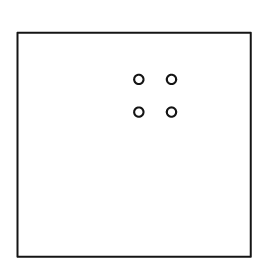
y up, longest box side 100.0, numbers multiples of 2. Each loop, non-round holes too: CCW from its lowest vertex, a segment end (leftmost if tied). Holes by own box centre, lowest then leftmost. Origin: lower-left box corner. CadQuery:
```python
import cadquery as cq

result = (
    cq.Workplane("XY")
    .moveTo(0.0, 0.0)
    .lineTo(100.0, 0.0)
    .lineTo(100.0, 96.0)
    .lineTo(0.0, 96.0)
    .close()
    .moveTo(52.0, 62.0)
    .circle(2.0)
    .moveTo(66.0, 62.0)
    .circle(2.0)
    .moveTo(52.0, 76.0)
    .circle(2.0)
    .moveTo(66.0, 76.0)
    .circle(2.0)
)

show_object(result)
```